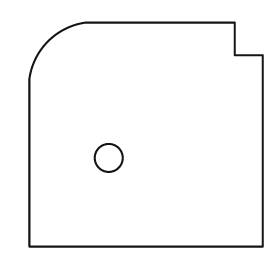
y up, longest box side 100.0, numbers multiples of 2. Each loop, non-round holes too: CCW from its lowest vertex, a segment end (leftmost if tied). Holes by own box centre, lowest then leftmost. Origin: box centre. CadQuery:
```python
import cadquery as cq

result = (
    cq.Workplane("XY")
    .moveTo(-50.0, -48.0)
    .lineTo(50.0, -48.0)
    .lineTo(50.0, 34.0)
    .lineTo(38.0, 34.0)
    .lineTo(38.0, 48.0)
    .lineTo(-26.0, 48.0)
    .threePointArc((-42.0, 40.0), (-50.0, 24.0))
    .close()
    .moveTo(-16.0, -10.0)
    .circle(6.0)
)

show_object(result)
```